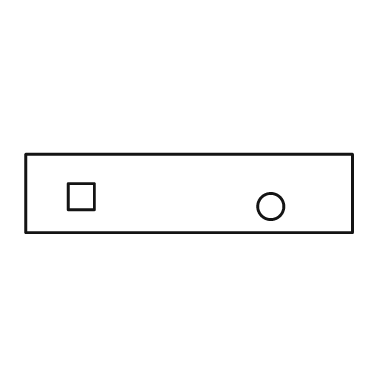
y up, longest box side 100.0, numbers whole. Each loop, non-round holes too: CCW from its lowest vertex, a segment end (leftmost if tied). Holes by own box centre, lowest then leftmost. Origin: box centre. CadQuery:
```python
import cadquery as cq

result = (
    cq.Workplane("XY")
    .moveTo(-50.0, -12.0)
    .lineTo(50.0, -12.0)
    .lineTo(50.0, 12.0)
    .lineTo(-50.0, 12.0)
    .close()
    .moveTo(25.0, -4.0)
    .circle(4.0)
    .moveTo(-37.0, -5.0)
    .lineTo(-29.0, -5.0)
    .lineTo(-29.0, 3.0)
    .lineTo(-37.0, 3.0)
    .close()
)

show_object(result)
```